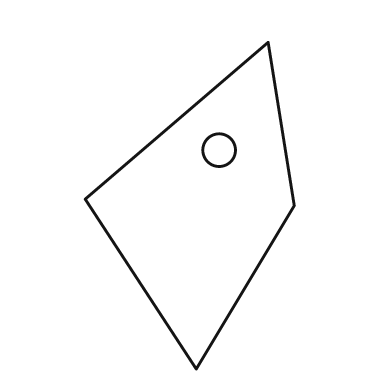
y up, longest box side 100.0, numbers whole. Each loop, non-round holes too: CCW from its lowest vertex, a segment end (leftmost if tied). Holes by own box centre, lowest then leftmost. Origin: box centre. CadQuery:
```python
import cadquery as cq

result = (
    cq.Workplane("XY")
    .moveTo(2.0, -50.0)
    .lineTo(32.0, 0.0)
    .lineTo(24.0, 50.0)
    .lineTo(-32.0, 2.0)
    .close()
    .moveTo(9.0, 17.0)
    .circle(5.0)
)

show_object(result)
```